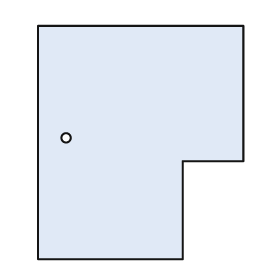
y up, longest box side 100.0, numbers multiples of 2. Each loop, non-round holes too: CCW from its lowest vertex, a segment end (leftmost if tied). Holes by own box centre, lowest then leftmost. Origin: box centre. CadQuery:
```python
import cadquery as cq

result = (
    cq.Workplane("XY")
    .moveTo(-44.0, -50.0)
    .lineTo(18.0, -50.0)
    .lineTo(18.0, -8.0)
    .lineTo(44.0, -8.0)
    .lineTo(44.0, 50.0)
    .lineTo(-44.0, 50.0)
    .close()
    .moveTo(-32.0, 2.0)
    .circle(2.0)
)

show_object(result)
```